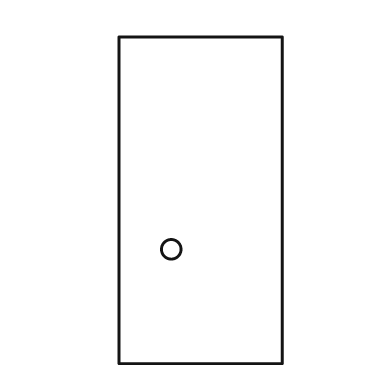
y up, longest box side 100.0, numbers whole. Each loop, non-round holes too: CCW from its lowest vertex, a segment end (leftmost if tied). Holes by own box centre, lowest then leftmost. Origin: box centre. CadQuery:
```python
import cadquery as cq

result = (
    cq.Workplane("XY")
    .moveTo(-25.0, -50.0)
    .lineTo(25.0, -50.0)
    .lineTo(25.0, 50.0)
    .lineTo(-25.0, 50.0)
    .close()
    .moveTo(-9.0, -15.0)
    .circle(3.0)
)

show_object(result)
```